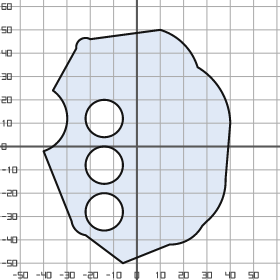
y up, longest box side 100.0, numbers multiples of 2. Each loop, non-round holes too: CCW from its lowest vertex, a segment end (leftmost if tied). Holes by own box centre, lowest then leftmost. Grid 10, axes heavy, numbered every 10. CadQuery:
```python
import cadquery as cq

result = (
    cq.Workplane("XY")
    .moveTo(-6.0, -50.0)
    .lineTo(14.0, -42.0)
    .threePointArc((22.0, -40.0), (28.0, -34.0))
    .lineTo(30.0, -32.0)
    .threePointArc((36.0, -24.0), (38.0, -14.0))
    .lineTo(40.0, 10.0)
    .threePointArc((36.0, 24.0), (26.0, 34.0))
    .threePointArc((20.0, 44.0), (10.0, 50.0))
    .lineTo(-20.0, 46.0)
    .threePointArc((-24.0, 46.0), (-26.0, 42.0))
    .lineTo(-36.0, 24.0)
    .threePointArc((-30.0, 10.0), (-40.0, -2.0))
    .lineTo(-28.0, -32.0)
    .threePointArc((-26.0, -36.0), (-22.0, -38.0))
    .close()
    .moveTo(-14.0, -28.0)
    .circle(8.0)
    .moveTo(-14.0, -8.0)
    .circle(8.0)
    .moveTo(-14.0, 12.0)
    .circle(8.0)
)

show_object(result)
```